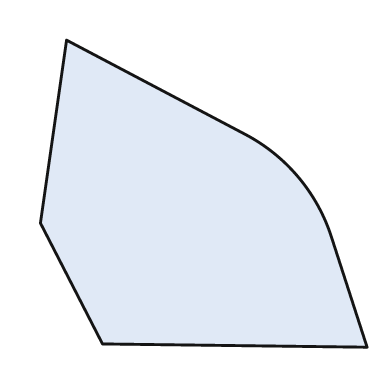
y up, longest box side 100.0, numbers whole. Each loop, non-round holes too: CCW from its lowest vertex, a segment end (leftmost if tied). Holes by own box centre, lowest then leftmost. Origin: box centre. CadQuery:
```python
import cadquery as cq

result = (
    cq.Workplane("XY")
    .moveTo(50.0, -47.0)
    .lineTo(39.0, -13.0)
    .threePointArc((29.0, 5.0), (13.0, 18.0))
    .lineTo(-42.0, 47.0)
    .lineTo(-50.0, -9.0)
    .lineTo(-31.0, -46.0)
    .close()
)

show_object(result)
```